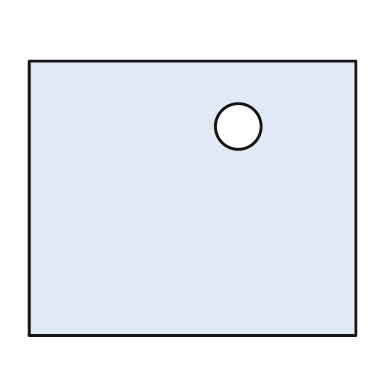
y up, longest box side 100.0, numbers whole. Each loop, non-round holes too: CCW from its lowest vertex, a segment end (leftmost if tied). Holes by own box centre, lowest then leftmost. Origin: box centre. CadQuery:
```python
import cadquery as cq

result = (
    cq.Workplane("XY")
    .moveTo(-50.0, -42.0)
    .lineTo(50.0, -42.0)
    .lineTo(50.0, 42.0)
    .lineTo(-50.0, 42.0)
    .close()
    .moveTo(14.0, 22.0)
    .circle(7.0)
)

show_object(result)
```